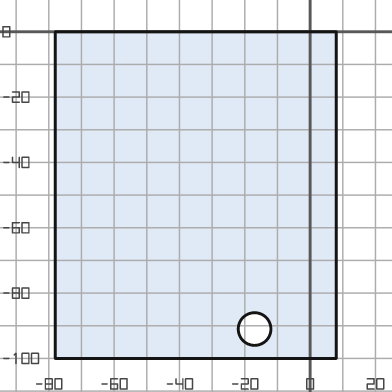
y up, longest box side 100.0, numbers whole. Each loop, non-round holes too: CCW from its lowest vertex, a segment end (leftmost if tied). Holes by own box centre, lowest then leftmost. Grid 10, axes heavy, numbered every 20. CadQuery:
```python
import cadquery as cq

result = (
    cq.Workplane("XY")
    .moveTo(-78.0, -100.0)
    .lineTo(8.0, -100.0)
    .lineTo(8.0, 0.0)
    .lineTo(-78.0, 0.0)
    .close()
    .moveTo(-17.0, -91.0)
    .circle(5.0)
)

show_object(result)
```